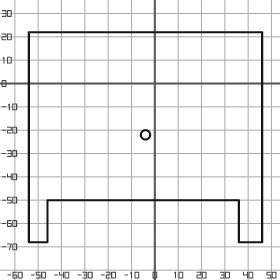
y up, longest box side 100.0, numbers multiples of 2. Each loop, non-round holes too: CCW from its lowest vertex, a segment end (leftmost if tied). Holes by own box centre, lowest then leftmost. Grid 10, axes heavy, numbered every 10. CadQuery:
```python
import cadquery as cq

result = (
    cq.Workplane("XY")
    .moveTo(-54.0, -68.0)
    .lineTo(-46.0, -68.0)
    .lineTo(-46.0, -50.0)
    .lineTo(36.0, -50.0)
    .lineTo(36.0, -68.0)
    .lineTo(46.0, -68.0)
    .lineTo(46.0, 22.0)
    .lineTo(-54.0, 22.0)
    .close()
    .moveTo(-4.0, -22.0)
    .circle(2.0)
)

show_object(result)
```